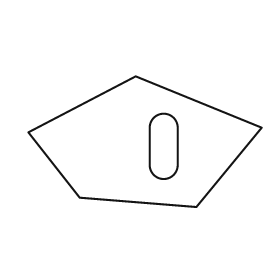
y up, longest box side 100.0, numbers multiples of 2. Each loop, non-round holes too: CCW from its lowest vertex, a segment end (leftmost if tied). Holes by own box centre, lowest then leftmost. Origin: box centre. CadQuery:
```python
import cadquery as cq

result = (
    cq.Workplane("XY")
    .moveTo(22.0, -28.0)
    .lineTo(50.0, 6.0)
    .lineTo(-4.0, 28.0)
    .lineTo(-50.0, 4.0)
    .lineTo(-28.0, -24.0)
    .close()
    .moveTo(2.0, -10.0)
    .threePointArc((8.0, -16.0), (14.0, -10.0))
    .lineTo(14.0, 6.0)
    .threePointArc((8.0, 12.0), (2.0, 6.0))
    .close()
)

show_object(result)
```